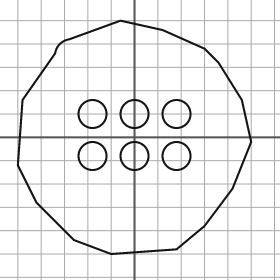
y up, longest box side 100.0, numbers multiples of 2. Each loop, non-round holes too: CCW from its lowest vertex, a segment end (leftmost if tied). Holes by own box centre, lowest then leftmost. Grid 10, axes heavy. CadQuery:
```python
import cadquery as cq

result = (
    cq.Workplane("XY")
    .moveTo(-10.0, -50.0)
    .lineTo(18.0, -48.0)
    .lineTo(30.0, -38.0)
    .lineTo(42.0, -22.0)
    .lineTo(50.0, -2.0)
    .lineTo(46.0, 16.0)
    .lineTo(36.0, 32.0)
    .lineTo(30.0, 38.0)
    .lineTo(12.0, 46.0)
    .lineTo(-6.0, 50.0)
    .lineTo(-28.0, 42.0)
    .threePointArc((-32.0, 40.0), (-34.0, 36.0))
    .lineTo(-48.0, 16.0)
    .lineTo(-50.0, -12.0)
    .lineTo(-42.0, -28.0)
    .lineTo(-26.0, -44.0)
    .close()
    .moveTo(-18.0, -8.0)
    .circle(6.0)
    .moveTo(0.0, -8.0)
    .circle(6.0)
    .moveTo(18.0, -8.0)
    .circle(6.0)
    .moveTo(-18.0, 10.0)
    .circle(6.0)
    .moveTo(0.0, 10.0)
    .circle(6.0)
    .moveTo(18.0, 10.0)
    .circle(6.0)
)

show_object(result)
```